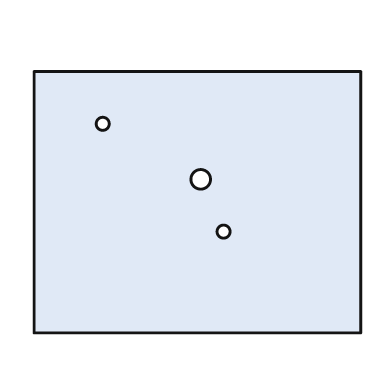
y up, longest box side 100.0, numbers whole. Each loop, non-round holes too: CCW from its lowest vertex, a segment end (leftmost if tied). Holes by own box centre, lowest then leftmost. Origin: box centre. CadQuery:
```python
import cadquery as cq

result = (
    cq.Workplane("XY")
    .moveTo(-50.0, -40.0)
    .lineTo(50.0, -40.0)
    .lineTo(50.0, 40.0)
    .lineTo(-50.0, 40.0)
    .close()
    .moveTo(8.0, -9.0)
    .circle(2.0)
    .moveTo(1.0, 7.0)
    .circle(3.0)
    .moveTo(-29.0, 24.0)
    .circle(2.0)
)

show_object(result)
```